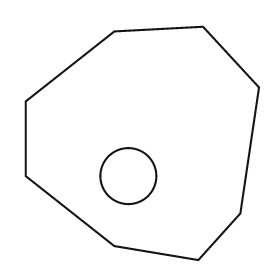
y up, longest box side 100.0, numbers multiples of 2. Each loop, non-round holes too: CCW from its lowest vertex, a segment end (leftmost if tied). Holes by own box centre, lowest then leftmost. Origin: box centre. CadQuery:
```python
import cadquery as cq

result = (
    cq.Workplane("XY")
    .moveTo(24.0, -50.0)
    .lineTo(42.0, -30.0)
    .lineTo(50.0, 24.0)
    .lineTo(26.0, 50.0)
    .lineTo(-12.0, 48.0)
    .lineTo(-50.0, 18.0)
    .lineTo(-50.0, -14.0)
    .lineTo(-12.0, -44.0)
    .close()
    .moveTo(-6.0, -14.0)
    .circle(12.0)
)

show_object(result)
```